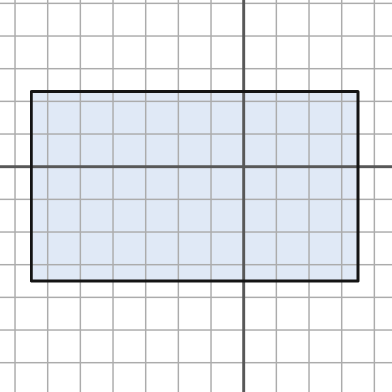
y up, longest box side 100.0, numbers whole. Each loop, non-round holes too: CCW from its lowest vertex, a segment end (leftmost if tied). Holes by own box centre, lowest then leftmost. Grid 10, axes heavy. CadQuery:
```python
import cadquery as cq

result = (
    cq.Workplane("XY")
    .moveTo(-65.0, -35.0)
    .lineTo(35.0, -35.0)
    .lineTo(35.0, 23.0)
    .lineTo(-65.0, 23.0)
    .close()
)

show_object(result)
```